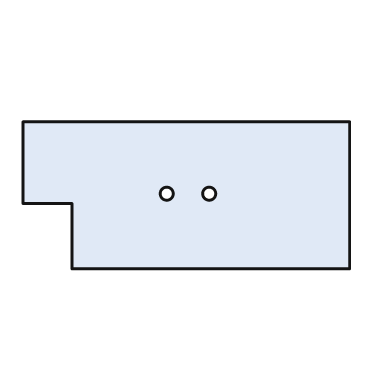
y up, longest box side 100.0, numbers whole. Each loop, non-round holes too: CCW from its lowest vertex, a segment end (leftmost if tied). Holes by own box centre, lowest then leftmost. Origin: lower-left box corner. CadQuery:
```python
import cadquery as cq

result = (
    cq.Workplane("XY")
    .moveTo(15.0, 0.0)
    .lineTo(100.0, 0.0)
    .lineTo(100.0, 45.0)
    .lineTo(0.0, 45.0)
    .lineTo(0.0, 20.0)
    .lineTo(15.0, 20.0)
    .close()
    .moveTo(44.0, 23.0)
    .circle(2.0)
    .moveTo(57.0, 23.0)
    .circle(2.0)
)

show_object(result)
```